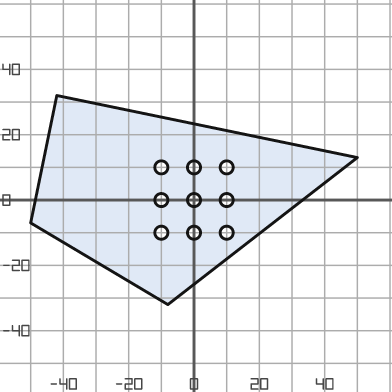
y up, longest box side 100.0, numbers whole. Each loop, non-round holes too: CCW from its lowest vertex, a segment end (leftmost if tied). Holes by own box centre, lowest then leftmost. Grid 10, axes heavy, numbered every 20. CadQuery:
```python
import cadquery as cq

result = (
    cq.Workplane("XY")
    .moveTo(-8.0, -32.0)
    .lineTo(50.0, 13.0)
    .lineTo(-42.0, 32.0)
    .lineTo(-50.0, -7.0)
    .close()
    .moveTo(-10.0, -10.0)
    .circle(2.0)
    .moveTo(0.0, -10.0)
    .circle(2.0)
    .moveTo(10.0, -10.0)
    .circle(2.0)
    .moveTo(-10.0, 0.0)
    .circle(2.0)
    .moveTo(0.0, 0.0)
    .circle(2.0)
    .moveTo(10.0, 0.0)
    .circle(2.0)
    .moveTo(-10.0, 10.0)
    .circle(2.0)
    .moveTo(0.0, 10.0)
    .circle(2.0)
    .moveTo(10.0, 10.0)
    .circle(2.0)
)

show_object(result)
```